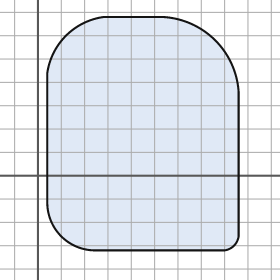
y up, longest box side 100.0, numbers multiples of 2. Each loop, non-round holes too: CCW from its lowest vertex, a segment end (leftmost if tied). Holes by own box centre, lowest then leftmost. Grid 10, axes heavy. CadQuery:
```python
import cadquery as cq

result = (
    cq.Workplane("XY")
    .moveTo(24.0, -32.0)
    .lineTo(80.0, -32.0)
    .threePointArc((84.0, -30.0), (86.0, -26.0))
    .lineTo(86.0, 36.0)
    .threePointArc((76.0, 58.0), (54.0, 68.0))
    .lineTo(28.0, 68.0)
    .threePointArc((12.0, 60.0), (4.0, 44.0))
    .lineTo(4.0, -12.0)
    .threePointArc((10.0, -26.0), (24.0, -32.0))
    .close()
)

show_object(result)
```